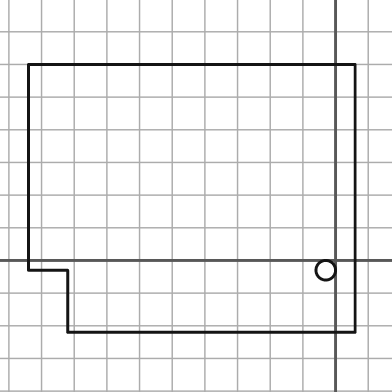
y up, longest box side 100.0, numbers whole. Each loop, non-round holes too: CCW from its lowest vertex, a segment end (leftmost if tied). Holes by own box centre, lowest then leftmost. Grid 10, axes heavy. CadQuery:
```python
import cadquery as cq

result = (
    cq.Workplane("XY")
    .moveTo(-82.0, -22.0)
    .lineTo(6.0, -22.0)
    .lineTo(6.0, 60.0)
    .lineTo(-94.0, 60.0)
    .lineTo(-94.0, -3.0)
    .lineTo(-82.0, -3.0)
    .close()
    .moveTo(-3.0, -3.0)
    .circle(3.0)
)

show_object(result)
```